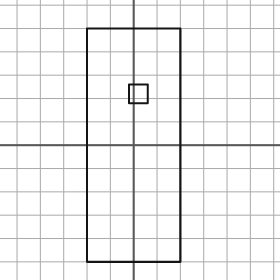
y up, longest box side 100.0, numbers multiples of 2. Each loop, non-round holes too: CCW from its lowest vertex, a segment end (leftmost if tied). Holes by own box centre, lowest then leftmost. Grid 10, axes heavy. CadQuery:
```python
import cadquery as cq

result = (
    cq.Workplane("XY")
    .moveTo(-20.0, -50.0)
    .lineTo(20.0, -50.0)
    .lineTo(20.0, 50.0)
    .lineTo(-20.0, 50.0)
    .close()
    .moveTo(-2.0, 18.0)
    .lineTo(6.0, 18.0)
    .lineTo(6.0, 26.0)
    .lineTo(-2.0, 26.0)
    .close()
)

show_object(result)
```